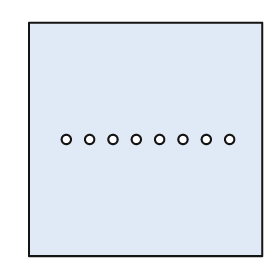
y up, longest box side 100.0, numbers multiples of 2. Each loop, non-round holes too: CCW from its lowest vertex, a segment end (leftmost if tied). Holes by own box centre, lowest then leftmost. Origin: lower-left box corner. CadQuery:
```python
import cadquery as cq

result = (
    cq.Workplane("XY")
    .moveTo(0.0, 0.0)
    .lineTo(100.0, 0.0)
    .lineTo(100.0, 100.0)
    .lineTo(0.0, 100.0)
    .close()
    .moveTo(16.0, 50.0)
    .circle(2.0)
    .moveTo(26.0, 50.0)
    .circle(2.0)
    .moveTo(36.0, 50.0)
    .circle(2.0)
    .moveTo(46.0, 50.0)
    .circle(2.0)
    .moveTo(56.0, 50.0)
    .circle(2.0)
    .moveTo(66.0, 50.0)
    .circle(2.0)
    .moveTo(76.0, 50.0)
    .circle(2.0)
    .moveTo(86.0, 50.0)
    .circle(2.0)
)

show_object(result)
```